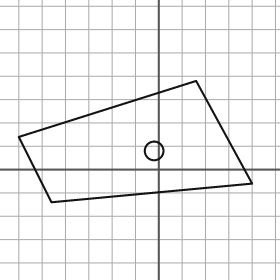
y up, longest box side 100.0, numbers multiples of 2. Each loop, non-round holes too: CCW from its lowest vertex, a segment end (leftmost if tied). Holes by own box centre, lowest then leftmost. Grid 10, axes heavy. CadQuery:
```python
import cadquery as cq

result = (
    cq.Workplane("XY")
    .moveTo(-46.0, -14.0)
    .lineTo(40.0, -6.0)
    .lineTo(16.0, 38.0)
    .lineTo(-60.0, 14.0)
    .close()
    .moveTo(-2.0, 8.0)
    .circle(4.0)
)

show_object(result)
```